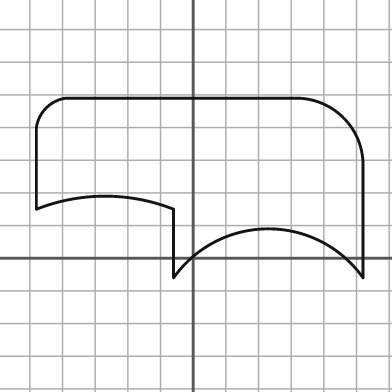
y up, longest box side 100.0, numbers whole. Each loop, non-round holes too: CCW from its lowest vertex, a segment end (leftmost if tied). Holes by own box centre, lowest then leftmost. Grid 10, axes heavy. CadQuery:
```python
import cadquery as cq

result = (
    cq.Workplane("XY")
    .moveTo(-6.0, -6.0)
    .threePointArc((23.0, 9.0), (52.0, -6.0))
    .lineTo(52.0, 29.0)
    .threePointArc((46.0, 43.0), (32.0, 49.0))
    .lineTo(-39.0, 49.0)
    .threePointArc((-45.0, 46.0), (-48.0, 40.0))
    .lineTo(-48.0, 15.0)
    .threePointArc((-27.0, 19.0), (-6.0, 15.0))
    .close()
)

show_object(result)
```